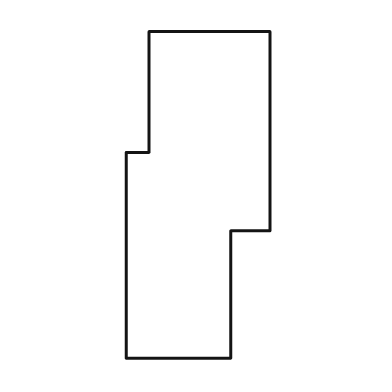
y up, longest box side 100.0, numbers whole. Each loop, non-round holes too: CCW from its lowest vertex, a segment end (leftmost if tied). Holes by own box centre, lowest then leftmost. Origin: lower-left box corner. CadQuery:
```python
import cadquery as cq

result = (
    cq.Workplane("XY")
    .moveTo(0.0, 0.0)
    .lineTo(32.0, 0.0)
    .lineTo(32.0, 39.0)
    .lineTo(44.0, 39.0)
    .lineTo(44.0, 100.0)
    .lineTo(7.0, 100.0)
    .lineTo(7.0, 63.0)
    .lineTo(0.0, 63.0)
    .close()
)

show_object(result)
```